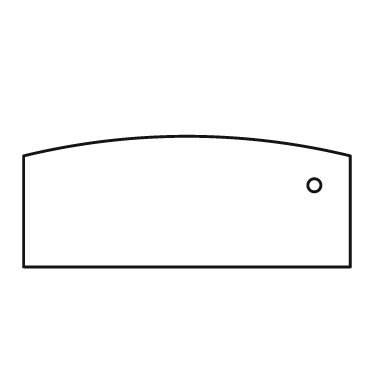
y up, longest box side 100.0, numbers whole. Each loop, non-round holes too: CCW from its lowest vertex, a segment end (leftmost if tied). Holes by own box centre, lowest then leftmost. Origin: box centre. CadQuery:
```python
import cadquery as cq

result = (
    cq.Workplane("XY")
    .moveTo(-50.0, -20.0)
    .lineTo(50.0, -20.0)
    .lineTo(50.0, 14.0)
    .threePointArc((0.0, 20.0), (-50.0, 14.0))
    .close()
    .moveTo(39.0, 5.0)
    .circle(2.0)
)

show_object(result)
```